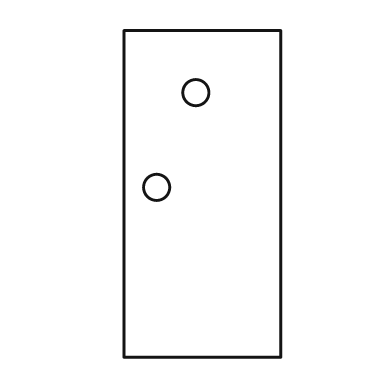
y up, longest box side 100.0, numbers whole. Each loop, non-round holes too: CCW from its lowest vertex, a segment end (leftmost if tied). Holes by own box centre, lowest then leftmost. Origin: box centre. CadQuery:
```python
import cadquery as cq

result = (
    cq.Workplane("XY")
    .moveTo(-24.0, -50.0)
    .lineTo(24.0, -50.0)
    .lineTo(24.0, 50.0)
    .lineTo(-24.0, 50.0)
    .close()
    .moveTo(-14.0, 2.0)
    .circle(4.0)
    .moveTo(-2.0, 31.0)
    .circle(4.0)
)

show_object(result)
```